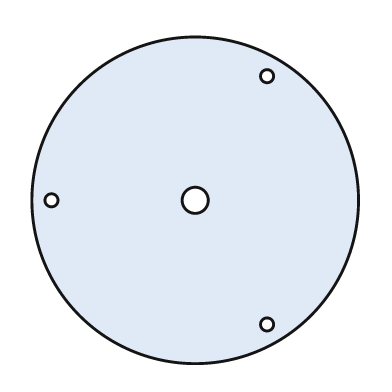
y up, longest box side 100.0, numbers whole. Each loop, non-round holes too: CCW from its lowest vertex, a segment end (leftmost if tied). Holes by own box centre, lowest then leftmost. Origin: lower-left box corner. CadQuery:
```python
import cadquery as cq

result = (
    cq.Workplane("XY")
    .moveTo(50.0, 50.0)
    .circle(50.0)
    .moveTo(72.0, 12.0)
    .circle(2.0)
    .moveTo(6.0, 50.0)
    .circle(2.0)
    .moveTo(50.0, 50.0)
    .circle(4.0)
    .moveTo(72.0, 88.0)
    .circle(2.0)
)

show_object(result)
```